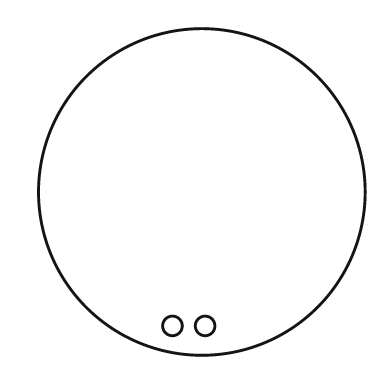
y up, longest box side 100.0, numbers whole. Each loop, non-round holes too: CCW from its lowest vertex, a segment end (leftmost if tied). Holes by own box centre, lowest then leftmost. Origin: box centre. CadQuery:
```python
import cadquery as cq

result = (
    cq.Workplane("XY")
    .moveTo(0.0, 0.0)
    .circle(50.0)
    .moveTo(-9.0, -41.0)
    .circle(3.0)
    .moveTo(1.0, -41.0)
    .circle(3.0)
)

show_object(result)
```